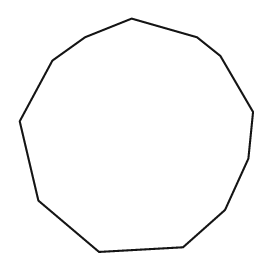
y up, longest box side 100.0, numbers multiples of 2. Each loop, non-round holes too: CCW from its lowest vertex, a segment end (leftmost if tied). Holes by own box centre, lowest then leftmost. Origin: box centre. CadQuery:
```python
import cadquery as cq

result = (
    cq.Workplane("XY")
    .moveTo(-16.0, -50.0)
    .lineTo(20.0, -48.0)
    .lineTo(38.0, -32.0)
    .lineTo(48.0, -10.0)
    .lineTo(50.0, 10.0)
    .lineTo(36.0, 34.0)
    .lineTo(26.0, 42.0)
    .lineTo(-2.0, 50.0)
    .lineTo(-22.0, 42.0)
    .lineTo(-36.0, 32.0)
    .lineTo(-50.0, 6.0)
    .lineTo(-42.0, -28.0)
    .close()
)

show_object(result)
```